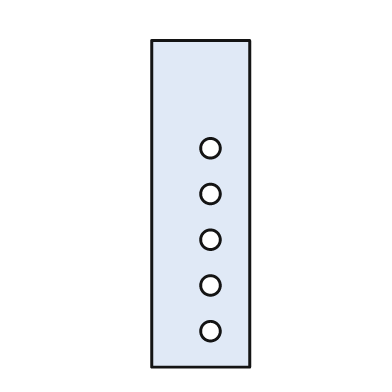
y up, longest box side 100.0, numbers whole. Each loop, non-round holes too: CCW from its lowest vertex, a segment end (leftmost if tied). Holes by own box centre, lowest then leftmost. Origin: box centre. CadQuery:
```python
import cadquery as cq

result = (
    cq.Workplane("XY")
    .moveTo(-15.0, -50.0)
    .lineTo(15.0, -50.0)
    .lineTo(15.0, 50.0)
    .lineTo(-15.0, 50.0)
    .close()
    .moveTo(3.0, -39.0)
    .circle(3.0)
    .moveTo(3.0, -25.0)
    .circle(3.0)
    .moveTo(3.0, -11.0)
    .circle(3.0)
    .moveTo(3.0, 3.0)
    .circle(3.0)
    .moveTo(3.0, 17.0)
    .circle(3.0)
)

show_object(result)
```